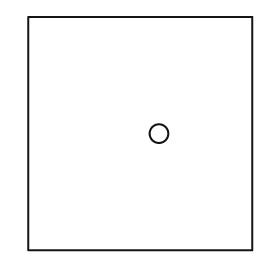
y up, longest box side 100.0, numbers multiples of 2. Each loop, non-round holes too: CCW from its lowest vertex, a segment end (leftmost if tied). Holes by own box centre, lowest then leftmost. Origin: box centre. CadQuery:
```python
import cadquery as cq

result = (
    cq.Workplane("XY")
    .moveTo(-48.0, -50.0)
    .lineTo(48.0, -50.0)
    .lineTo(48.0, 50.0)
    .lineTo(-48.0, 50.0)
    .close()
    .moveTo(8.0, 0.0)
    .circle(4.0)
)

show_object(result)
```